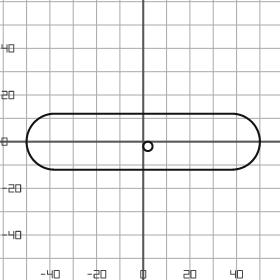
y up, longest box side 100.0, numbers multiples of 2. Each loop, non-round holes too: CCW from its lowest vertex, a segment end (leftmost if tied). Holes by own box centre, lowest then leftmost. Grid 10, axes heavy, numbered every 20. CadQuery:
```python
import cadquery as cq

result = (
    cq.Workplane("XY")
    .moveTo(-38.0, -12.0)
    .lineTo(38.0, -12.0)
    .threePointArc((50.0, 0.0), (38.0, 12.0))
    .lineTo(-38.0, 12.0)
    .threePointArc((-50.0, 0.0), (-38.0, -12.0))
    .close()
    .moveTo(2.0, -2.0)
    .circle(2.0)
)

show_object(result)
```